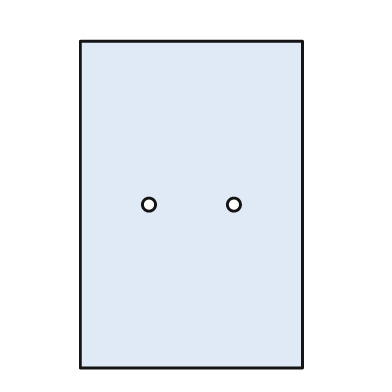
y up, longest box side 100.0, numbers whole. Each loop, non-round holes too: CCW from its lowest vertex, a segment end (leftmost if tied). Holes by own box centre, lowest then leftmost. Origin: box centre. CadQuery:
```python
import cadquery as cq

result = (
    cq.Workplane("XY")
    .moveTo(-34.0, -50.0)
    .lineTo(34.0, -50.0)
    .lineTo(34.0, 50.0)
    .lineTo(-34.0, 50.0)
    .close()
    .moveTo(-13.0, 0.0)
    .circle(2.0)
    .moveTo(13.0, 0.0)
    .circle(2.0)
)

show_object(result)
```